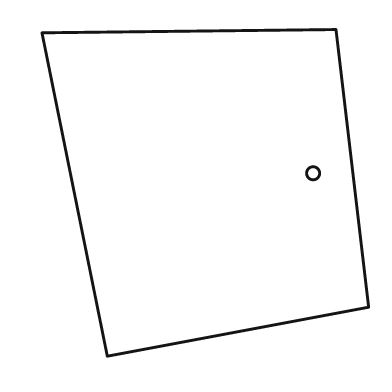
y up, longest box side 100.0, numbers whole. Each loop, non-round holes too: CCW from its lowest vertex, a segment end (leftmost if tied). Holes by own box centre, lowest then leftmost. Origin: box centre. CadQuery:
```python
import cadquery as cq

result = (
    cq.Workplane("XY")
    .moveTo(-30.0, -50.0)
    .lineTo(50.0, -35.0)
    .lineTo(40.0, 50.0)
    .lineTo(-50.0, 49.0)
    .close()
    .moveTo(33.0, 6.0)
    .circle(2.0)
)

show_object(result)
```